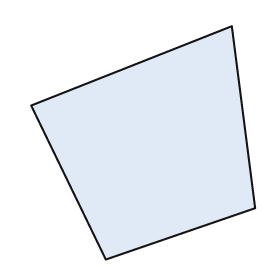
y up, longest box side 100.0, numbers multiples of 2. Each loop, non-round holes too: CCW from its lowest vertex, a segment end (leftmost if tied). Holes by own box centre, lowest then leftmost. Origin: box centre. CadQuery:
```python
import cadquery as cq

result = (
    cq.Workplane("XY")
    .moveTo(-16.0, -50.0)
    .lineTo(48.0, -28.0)
    .lineTo(38.0, 50.0)
    .lineTo(-48.0, 16.0)
    .close()
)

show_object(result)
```